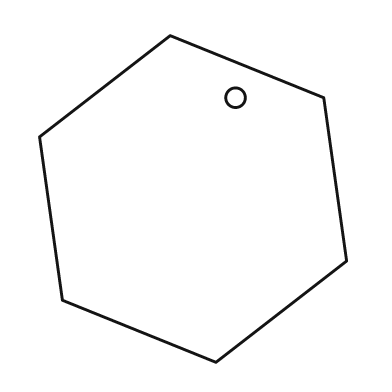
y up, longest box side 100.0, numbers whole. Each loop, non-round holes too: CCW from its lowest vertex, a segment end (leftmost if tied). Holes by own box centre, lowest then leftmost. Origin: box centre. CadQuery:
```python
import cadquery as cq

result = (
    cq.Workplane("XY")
    .moveTo(7.0, -50.0)
    .lineTo(47.0, -19.0)
    .lineTo(40.0, 31.0)
    .lineTo(-7.0, 50.0)
    .lineTo(-47.0, 19.0)
    .lineTo(-40.0, -31.0)
    .close()
    .moveTo(13.0, 31.0)
    .circle(3.0)
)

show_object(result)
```